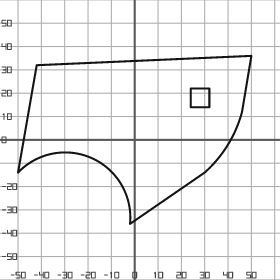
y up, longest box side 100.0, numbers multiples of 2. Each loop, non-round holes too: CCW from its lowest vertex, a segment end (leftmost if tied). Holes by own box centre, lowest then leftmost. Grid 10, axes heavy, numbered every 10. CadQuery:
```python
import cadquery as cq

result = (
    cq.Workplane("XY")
    .moveTo(-2.0, -36.0)
    .lineTo(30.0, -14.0)
    .threePointArc((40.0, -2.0), (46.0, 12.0))
    .lineTo(50.0, 36.0)
    .lineTo(-42.0, 32.0)
    .lineTo(-50.0, -14.0)
    .threePointArc((-18.0, -8.0), (-2.0, -36.0))
    .close()
    .moveTo(24.0, 14.0)
    .lineTo(32.0, 14.0)
    .lineTo(32.0, 22.0)
    .lineTo(24.0, 22.0)
    .close()
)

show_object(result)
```